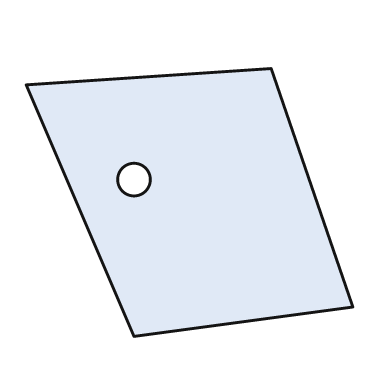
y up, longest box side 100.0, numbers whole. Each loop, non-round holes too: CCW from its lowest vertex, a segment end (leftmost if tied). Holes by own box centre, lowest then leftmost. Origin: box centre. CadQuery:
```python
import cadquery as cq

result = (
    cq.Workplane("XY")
    .moveTo(-17.0, -41.0)
    .lineTo(50.0, -32.0)
    .lineTo(25.0, 41.0)
    .lineTo(-50.0, 36.0)
    .close()
    .moveTo(-17.0, 7.0)
    .circle(5.0)
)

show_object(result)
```